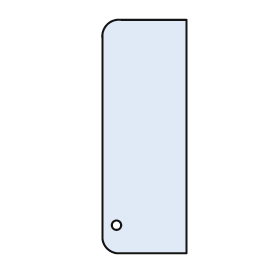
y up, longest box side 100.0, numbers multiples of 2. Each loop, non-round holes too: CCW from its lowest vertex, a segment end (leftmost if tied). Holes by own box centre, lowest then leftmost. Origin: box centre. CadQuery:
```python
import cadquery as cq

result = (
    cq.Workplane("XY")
    .moveTo(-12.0, -50.0)
    .lineTo(18.0, -50.0)
    .lineTo(18.0, 50.0)
    .lineTo(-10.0, 50.0)
    .threePointArc((-16.0, 48.0), (-18.0, 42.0))
    .lineTo(-18.0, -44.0)
    .threePointArc((-16.0, -48.0), (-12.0, -50.0))
    .close()
    .moveTo(-12.0, -38.0)
    .circle(2.0)
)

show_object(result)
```